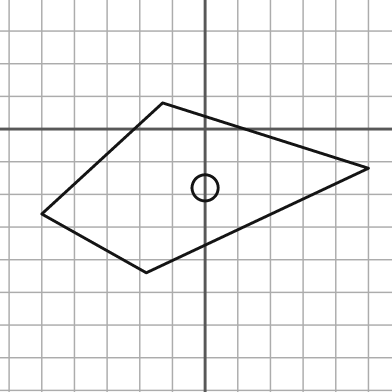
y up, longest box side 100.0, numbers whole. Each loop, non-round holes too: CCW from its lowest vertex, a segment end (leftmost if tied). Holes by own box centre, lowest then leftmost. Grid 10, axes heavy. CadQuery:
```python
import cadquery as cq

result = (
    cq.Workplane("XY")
    .moveTo(-18.0, -44.0)
    .lineTo(50.0, -12.0)
    .lineTo(-13.0, 8.0)
    .lineTo(-50.0, -26.0)
    .close()
    .moveTo(0.0, -18.0)
    .circle(4.0)
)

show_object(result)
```